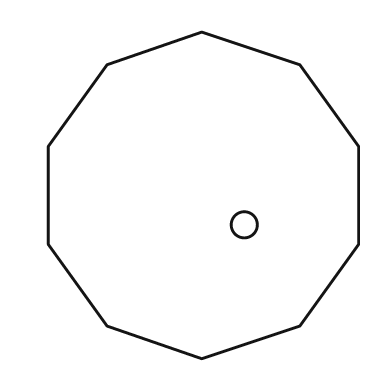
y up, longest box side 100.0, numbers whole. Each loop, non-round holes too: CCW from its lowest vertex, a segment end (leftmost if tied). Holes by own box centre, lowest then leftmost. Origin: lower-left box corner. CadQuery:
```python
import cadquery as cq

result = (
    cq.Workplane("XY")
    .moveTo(47.0, 0.0)
    .lineTo(77.0, 10.0)
    .lineTo(95.0, 35.0)
    .lineTo(95.0, 65.0)
    .lineTo(77.0, 90.0)
    .lineTo(47.0, 100.0)
    .lineTo(18.0, 90.0)
    .lineTo(0.0, 65.0)
    .lineTo(0.0, 35.0)
    .lineTo(18.0, 10.0)
    .close()
    .moveTo(60.0, 41.0)
    .circle(4.0)
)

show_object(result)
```